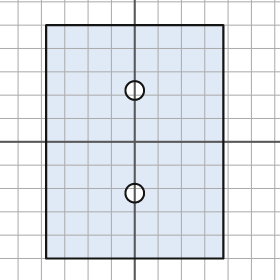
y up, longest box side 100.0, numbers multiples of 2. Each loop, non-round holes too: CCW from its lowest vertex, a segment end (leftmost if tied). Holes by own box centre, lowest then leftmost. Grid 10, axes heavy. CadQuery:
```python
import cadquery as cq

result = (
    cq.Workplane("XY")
    .moveTo(-38.0, -50.0)
    .lineTo(38.0, -50.0)
    .lineTo(38.0, 50.0)
    .lineTo(-38.0, 50.0)
    .close()
    .moveTo(0.0, -22.0)
    .circle(4.0)
    .moveTo(0.0, 22.0)
    .circle(4.0)
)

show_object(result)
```